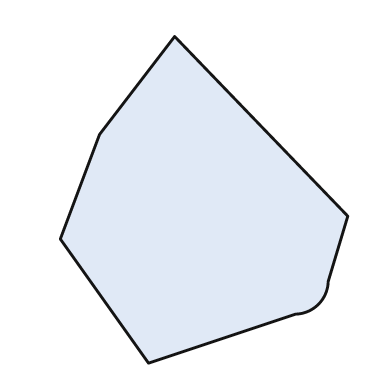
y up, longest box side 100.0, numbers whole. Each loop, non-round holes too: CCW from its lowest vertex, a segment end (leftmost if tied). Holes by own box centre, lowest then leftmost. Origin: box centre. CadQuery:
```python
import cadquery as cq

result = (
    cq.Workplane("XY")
    .moveTo(-17.0, -50.0)
    .lineTo(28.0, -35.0)
    .threePointArc((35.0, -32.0), (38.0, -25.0))
    .lineTo(44.0, -5.0)
    .lineTo(-9.0, 50.0)
    .lineTo(-32.0, 20.0)
    .lineTo(-44.0, -12.0)
    .close()
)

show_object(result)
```